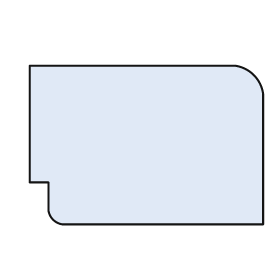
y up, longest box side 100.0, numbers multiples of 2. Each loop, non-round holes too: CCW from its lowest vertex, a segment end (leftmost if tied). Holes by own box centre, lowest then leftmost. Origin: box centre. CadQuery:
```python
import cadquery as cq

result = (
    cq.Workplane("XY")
    .moveTo(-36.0, -34.0)
    .lineTo(50.0, -34.0)
    .lineTo(50.0, 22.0)
    .threePointArc((46.0, 30.0), (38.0, 34.0))
    .lineTo(-50.0, 34.0)
    .lineTo(-50.0, -16.0)
    .lineTo(-42.0, -16.0)
    .lineTo(-42.0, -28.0)
    .threePointArc((-40.0, -32.0), (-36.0, -34.0))
    .close()
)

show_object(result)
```